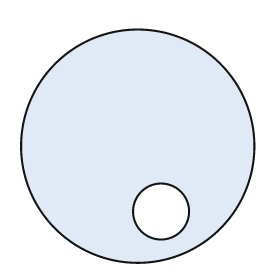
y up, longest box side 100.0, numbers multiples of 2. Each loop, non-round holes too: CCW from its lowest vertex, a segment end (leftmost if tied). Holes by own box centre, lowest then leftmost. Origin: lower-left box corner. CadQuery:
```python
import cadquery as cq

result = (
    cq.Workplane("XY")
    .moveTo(50.0, 50.0)
    .circle(50.0)
    .moveTo(60.0, 22.0)
    .circle(12.0)
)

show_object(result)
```